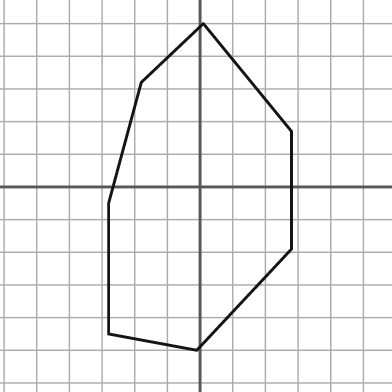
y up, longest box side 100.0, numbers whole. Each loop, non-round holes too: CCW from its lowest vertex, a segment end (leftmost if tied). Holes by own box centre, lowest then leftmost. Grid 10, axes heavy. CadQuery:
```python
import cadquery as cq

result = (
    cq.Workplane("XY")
    .moveTo(-1.0, -50.0)
    .lineTo(28.0, -19.0)
    .lineTo(28.0, 17.0)
    .lineTo(1.0, 50.0)
    .lineTo(-18.0, 32.0)
    .lineTo(-28.0, -5.0)
    .lineTo(-28.0, -45.0)
    .close()
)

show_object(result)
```